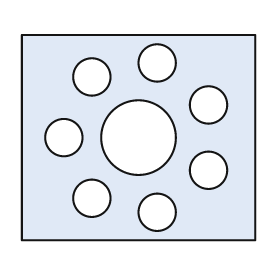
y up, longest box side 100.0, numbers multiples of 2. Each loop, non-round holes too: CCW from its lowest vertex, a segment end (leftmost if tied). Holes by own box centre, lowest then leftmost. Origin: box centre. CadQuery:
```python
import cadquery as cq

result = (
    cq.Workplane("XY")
    .moveTo(-50.0, -44.0)
    .lineTo(50.0, -44.0)
    .lineTo(50.0, 44.0)
    .lineTo(-50.0, 44.0)
    .close()
    .moveTo(8.0, -32.0)
    .circle(8.0)
    .moveTo(-20.0, -26.0)
    .circle(8.0)
    .moveTo(30.0, -14.0)
    .circle(8.0)
    .moveTo(-32.0, 0.0)
    .circle(8.0)
    .moveTo(0.0, 0.0)
    .circle(16.0)
    .moveTo(30.0, 14.0)
    .circle(8.0)
    .moveTo(-20.0, 26.0)
    .circle(8.0)
    .moveTo(8.0, 32.0)
    .circle(8.0)
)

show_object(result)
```